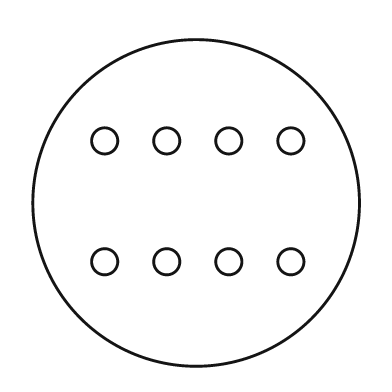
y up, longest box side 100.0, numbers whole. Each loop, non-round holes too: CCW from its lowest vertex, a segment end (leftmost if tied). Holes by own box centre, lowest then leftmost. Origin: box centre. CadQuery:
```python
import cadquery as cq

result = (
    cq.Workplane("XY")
    .moveTo(0.0, 0.0)
    .circle(50.0)
    .moveTo(-28.0, -18.0)
    .circle(4.0)
    .moveTo(-9.0, -18.0)
    .circle(4.0)
    .moveTo(10.0, -18.0)
    .circle(4.0)
    .moveTo(29.0, -18.0)
    .circle(4.0)
    .moveTo(-28.0, 19.0)
    .circle(4.0)
    .moveTo(-9.0, 19.0)
    .circle(4.0)
    .moveTo(10.0, 19.0)
    .circle(4.0)
    .moveTo(29.0, 19.0)
    .circle(4.0)
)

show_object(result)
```